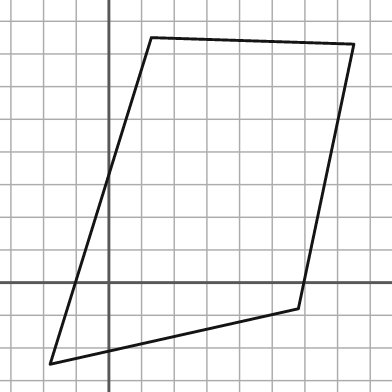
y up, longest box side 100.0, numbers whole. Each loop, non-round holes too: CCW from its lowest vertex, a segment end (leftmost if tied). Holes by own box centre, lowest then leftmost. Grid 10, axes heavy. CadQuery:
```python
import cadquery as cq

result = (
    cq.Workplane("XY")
    .moveTo(-18.0, -25.0)
    .lineTo(58.0, -8.0)
    .lineTo(75.0, 73.0)
    .lineTo(13.0, 75.0)
    .close()
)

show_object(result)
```